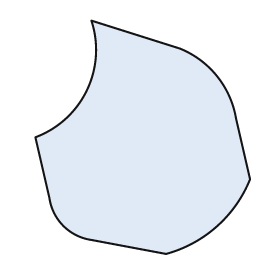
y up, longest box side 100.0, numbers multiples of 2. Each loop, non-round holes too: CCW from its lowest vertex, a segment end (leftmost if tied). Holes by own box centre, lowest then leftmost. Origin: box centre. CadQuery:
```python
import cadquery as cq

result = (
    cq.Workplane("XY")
    .moveTo(10.0, -50.0)
    .threePointArc((32.0, -38.0), (46.0, -18.0))
    .lineTo(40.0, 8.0)
    .threePointArc((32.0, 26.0), (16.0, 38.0))
    .lineTo(-22.0, 50.0)
    .threePointArc((-24.0, 20.0), (-46.0, 0.0))
    .lineTo(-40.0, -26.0)
    .threePointArc((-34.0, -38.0), (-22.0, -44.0))
    .close()
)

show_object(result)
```